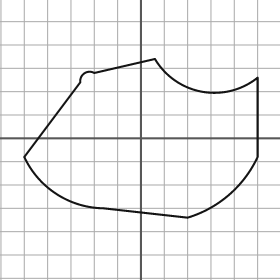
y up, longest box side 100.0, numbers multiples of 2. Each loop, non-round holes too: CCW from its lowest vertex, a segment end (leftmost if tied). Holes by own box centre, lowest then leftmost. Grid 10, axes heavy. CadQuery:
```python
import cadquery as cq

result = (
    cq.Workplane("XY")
    .moveTo(20.0, -34.0)
    .threePointArc((38.0, -24.0), (50.0, -8.0))
    .lineTo(50.0, 26.0)
    .threePointArc((26.0, 20.0), (6.0, 34.0))
    .lineTo(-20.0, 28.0)
    .threePointArc((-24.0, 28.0), (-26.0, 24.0))
    .lineTo(-50.0, -8.0)
    .threePointArc((-36.0, -24.0), (-16.0, -30.0))
    .close()
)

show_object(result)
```